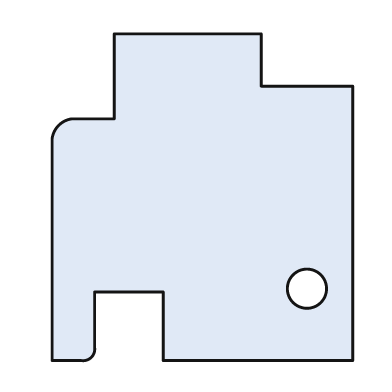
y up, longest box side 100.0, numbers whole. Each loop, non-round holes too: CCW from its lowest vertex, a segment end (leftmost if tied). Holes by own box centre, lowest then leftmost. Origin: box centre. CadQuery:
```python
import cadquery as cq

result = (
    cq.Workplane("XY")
    .moveTo(-46.0, -50.0)
    .lineTo(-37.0, -50.0)
    .threePointArc((-34.0, -49.0), (-33.0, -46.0))
    .lineTo(-33.0, -29.0)
    .lineTo(-12.0, -29.0)
    .lineTo(-12.0, -50.0)
    .lineTo(46.0, -50.0)
    .lineTo(46.0, 34.0)
    .lineTo(18.0, 34.0)
    .lineTo(18.0, 50.0)
    .lineTo(-27.0, 50.0)
    .lineTo(-27.0, 24.0)
    .lineTo(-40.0, 24.0)
    .threePointArc((-44.0, 22.0), (-46.0, 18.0))
    .close()
    .moveTo(32.0, -28.0)
    .circle(6.0)
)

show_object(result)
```